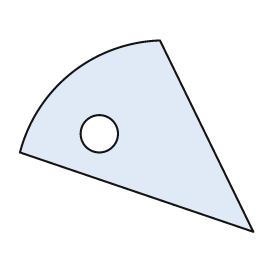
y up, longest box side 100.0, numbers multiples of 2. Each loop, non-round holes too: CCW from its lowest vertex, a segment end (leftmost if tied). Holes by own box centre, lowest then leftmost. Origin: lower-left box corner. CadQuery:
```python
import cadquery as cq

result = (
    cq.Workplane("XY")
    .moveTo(100.0, 0.0)
    .lineTo(60.0, 82.0)
    .threePointArc((22.0, 68.0), (0.0, 34.0))
    .close()
    .moveTo(34.0, 42.0)
    .circle(8.0)
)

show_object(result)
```